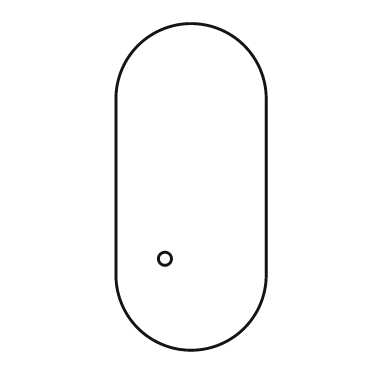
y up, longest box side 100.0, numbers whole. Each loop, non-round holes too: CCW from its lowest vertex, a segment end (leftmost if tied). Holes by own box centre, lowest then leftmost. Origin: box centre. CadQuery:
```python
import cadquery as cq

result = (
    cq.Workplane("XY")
    .moveTo(-23.0, -27.0)
    .threePointArc((0.0, -50.0), (23.0, -27.0))
    .lineTo(23.0, 27.0)
    .threePointArc((0.0, 50.0), (-23.0, 27.0))
    .close()
    .moveTo(-8.0, -22.0)
    .circle(2.0)
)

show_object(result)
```